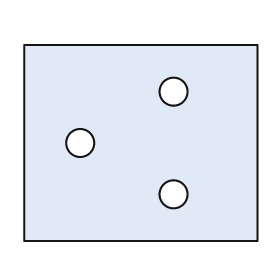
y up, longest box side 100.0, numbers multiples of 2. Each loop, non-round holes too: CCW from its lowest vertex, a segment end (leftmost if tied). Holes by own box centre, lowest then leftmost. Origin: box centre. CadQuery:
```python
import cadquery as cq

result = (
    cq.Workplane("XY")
    .moveTo(-50.0, -42.0)
    .lineTo(50.0, -42.0)
    .lineTo(50.0, 42.0)
    .lineTo(-50.0, 42.0)
    .close()
    .moveTo(14.0, -22.0)
    .circle(6.0)
    .moveTo(-26.0, 0.0)
    .circle(6.0)
    .moveTo(14.0, 22.0)
    .circle(6.0)
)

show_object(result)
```